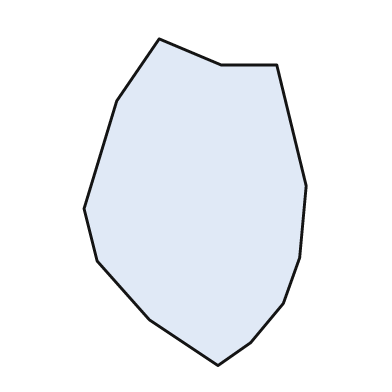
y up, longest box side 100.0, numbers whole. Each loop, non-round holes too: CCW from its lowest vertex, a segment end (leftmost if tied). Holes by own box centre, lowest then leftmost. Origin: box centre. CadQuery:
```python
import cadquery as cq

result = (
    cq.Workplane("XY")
    .moveTo(7.0, -50.0)
    .lineTo(17.0, -43.0)
    .lineTo(27.0, -31.0)
    .lineTo(32.0, -17.0)
    .lineTo(34.0, 5.0)
    .lineTo(25.0, 42.0)
    .lineTo(8.0, 42.0)
    .lineTo(-11.0, 50.0)
    .lineTo(-24.0, 31.0)
    .lineTo(-34.0, -2.0)
    .lineTo(-30.0, -18.0)
    .lineTo(-14.0, -36.0)
    .close()
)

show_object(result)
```